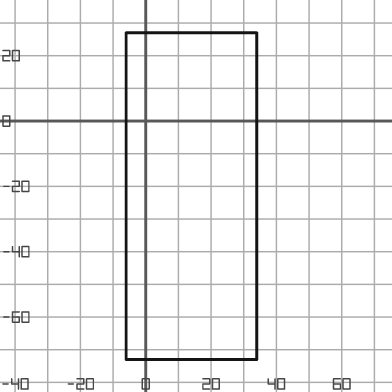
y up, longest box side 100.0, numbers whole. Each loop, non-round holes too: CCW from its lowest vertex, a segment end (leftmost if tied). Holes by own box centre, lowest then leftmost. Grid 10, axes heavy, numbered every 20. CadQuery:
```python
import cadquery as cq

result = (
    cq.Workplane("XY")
    .moveTo(-6.0, -73.0)
    .lineTo(34.0, -73.0)
    .lineTo(34.0, 27.0)
    .lineTo(-6.0, 27.0)
    .close()
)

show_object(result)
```